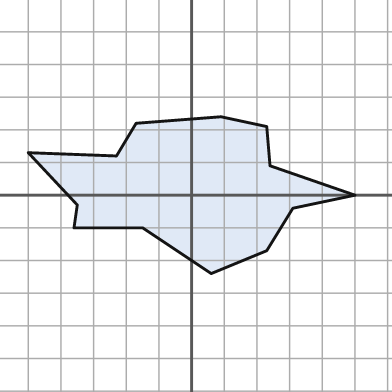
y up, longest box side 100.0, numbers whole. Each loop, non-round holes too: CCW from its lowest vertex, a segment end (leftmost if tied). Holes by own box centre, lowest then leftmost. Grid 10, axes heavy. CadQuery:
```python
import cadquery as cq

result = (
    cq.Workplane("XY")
    .moveTo(6.0, -24.0)
    .lineTo(23.0, -17.0)
    .lineTo(31.0, -4.0)
    .lineTo(50.0, 0.0)
    .lineTo(24.0, 9.0)
    .lineTo(23.0, 21.0)
    .lineTo(9.0, 24.0)
    .lineTo(-17.0, 22.0)
    .lineTo(-23.0, 12.0)
    .lineTo(-50.0, 13.0)
    .lineTo(-35.0, -3.0)
    .lineTo(-36.0, -10.0)
    .lineTo(-15.0, -10.0)
    .close()
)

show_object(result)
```